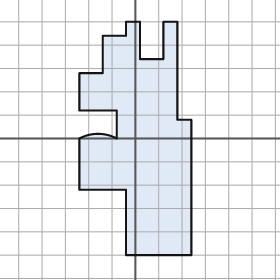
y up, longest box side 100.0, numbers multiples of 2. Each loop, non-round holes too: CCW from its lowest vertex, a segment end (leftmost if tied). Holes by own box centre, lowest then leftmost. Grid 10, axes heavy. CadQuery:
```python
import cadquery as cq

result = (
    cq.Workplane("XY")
    .moveTo(-4.0, -50.0)
    .lineTo(24.0, -50.0)
    .lineTo(24.0, 8.0)
    .lineTo(18.0, 8.0)
    .lineTo(18.0, 50.0)
    .lineTo(12.0, 50.0)
    .lineTo(12.0, 34.0)
    .lineTo(2.0, 34.0)
    .lineTo(2.0, 50.0)
    .lineTo(-4.0, 50.0)
    .lineTo(-4.0, 44.0)
    .lineTo(-14.0, 44.0)
    .lineTo(-14.0, 28.0)
    .lineTo(-24.0, 28.0)
    .lineTo(-24.0, 12.0)
    .lineTo(-8.0, 12.0)
    .lineTo(-8.0, 0.0)
    .threePointArc((-16.0, 2.0), (-24.0, 0.0))
    .lineTo(-24.0, -22.0)
    .lineTo(-4.0, -22.0)
    .close()
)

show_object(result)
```